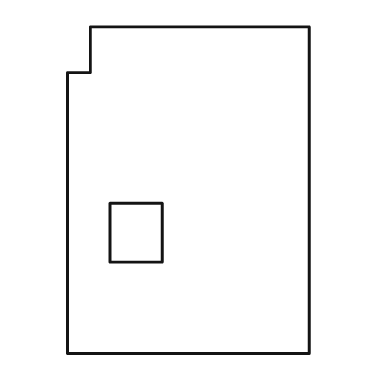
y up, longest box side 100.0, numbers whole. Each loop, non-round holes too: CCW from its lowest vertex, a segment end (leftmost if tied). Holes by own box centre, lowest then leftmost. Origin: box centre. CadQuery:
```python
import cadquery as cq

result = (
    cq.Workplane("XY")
    .moveTo(-37.0, -50.0)
    .lineTo(37.0, -50.0)
    .lineTo(37.0, 50.0)
    .lineTo(-30.0, 50.0)
    .lineTo(-30.0, 36.0)
    .lineTo(-37.0, 36.0)
    .close()
    .moveTo(-24.0, -22.0)
    .lineTo(-8.0, -22.0)
    .lineTo(-8.0, -4.0)
    .lineTo(-24.0, -4.0)
    .close()
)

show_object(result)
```